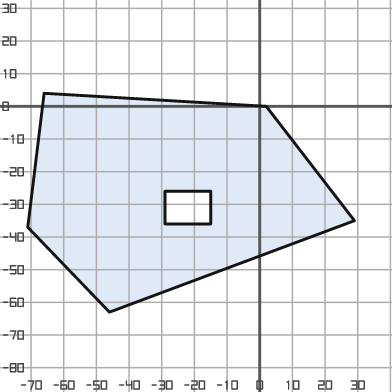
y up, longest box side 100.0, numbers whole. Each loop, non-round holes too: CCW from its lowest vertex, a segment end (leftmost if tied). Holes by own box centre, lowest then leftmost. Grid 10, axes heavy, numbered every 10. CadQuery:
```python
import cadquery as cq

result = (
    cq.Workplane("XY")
    .moveTo(-46.0, -63.0)
    .lineTo(29.0, -35.0)
    .lineTo(2.0, 0.0)
    .lineTo(-66.0, 4.0)
    .lineTo(-71.0, -37.0)
    .close()
    .moveTo(-29.0, -36.0)
    .lineTo(-15.0, -36.0)
    .lineTo(-15.0, -26.0)
    .lineTo(-29.0, -26.0)
    .close()
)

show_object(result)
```